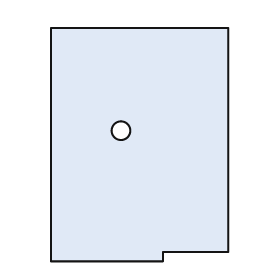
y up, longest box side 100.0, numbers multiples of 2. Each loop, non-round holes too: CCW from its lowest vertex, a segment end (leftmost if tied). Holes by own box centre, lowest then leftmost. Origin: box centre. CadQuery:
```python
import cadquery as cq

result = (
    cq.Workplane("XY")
    .moveTo(-38.0, -50.0)
    .lineTo(10.0, -50.0)
    .lineTo(10.0, -46.0)
    .lineTo(38.0, -46.0)
    .lineTo(38.0, 50.0)
    .lineTo(-38.0, 50.0)
    .close()
    .moveTo(-8.0, 6.0)
    .circle(4.0)
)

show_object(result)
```